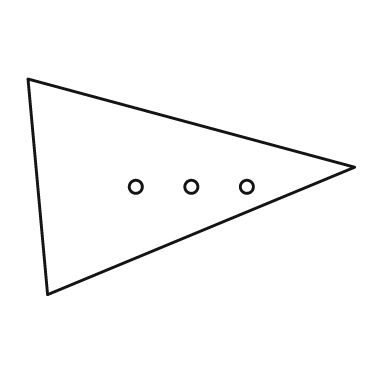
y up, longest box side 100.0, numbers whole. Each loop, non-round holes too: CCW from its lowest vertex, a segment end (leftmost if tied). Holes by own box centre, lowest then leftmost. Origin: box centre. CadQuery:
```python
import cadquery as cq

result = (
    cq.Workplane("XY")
    .moveTo(-44.0, -33.0)
    .lineTo(50.0, 6.0)
    .lineTo(-50.0, 33.0)
    .close()
    .moveTo(-17.0, 0.0)
    .circle(2.0)
    .moveTo(0.0, 0.0)
    .circle(2.0)
    .moveTo(17.0, 0.0)
    .circle(2.0)
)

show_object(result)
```